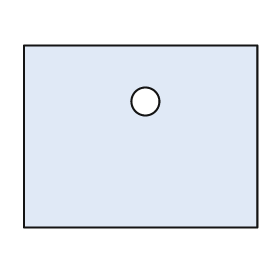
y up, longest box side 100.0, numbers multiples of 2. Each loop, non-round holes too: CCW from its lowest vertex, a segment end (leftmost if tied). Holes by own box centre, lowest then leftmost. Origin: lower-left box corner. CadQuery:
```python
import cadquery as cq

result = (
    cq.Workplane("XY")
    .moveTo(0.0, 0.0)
    .lineTo(100.0, 0.0)
    .lineTo(100.0, 78.0)
    .lineTo(0.0, 78.0)
    .close()
    .moveTo(52.0, 54.0)
    .circle(6.0)
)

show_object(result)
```